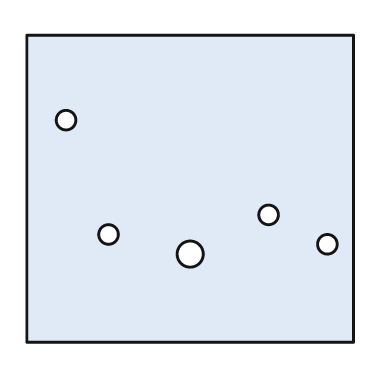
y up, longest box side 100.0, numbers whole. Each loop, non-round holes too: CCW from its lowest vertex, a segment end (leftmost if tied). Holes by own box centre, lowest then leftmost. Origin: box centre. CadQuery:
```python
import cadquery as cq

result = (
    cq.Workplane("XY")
    .moveTo(-50.0, -47.0)
    .lineTo(50.0, -47.0)
    .lineTo(50.0, 47.0)
    .lineTo(-50.0, 47.0)
    .close()
    .moveTo(0.0, -20.0)
    .circle(4.0)
    .moveTo(42.0, -17.0)
    .circle(3.0)
    .moveTo(-25.0, -14.0)
    .circle(3.0)
    .moveTo(24.0, -8.0)
    .circle(3.0)
    .moveTo(-38.0, 21.0)
    .circle(3.0)
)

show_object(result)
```